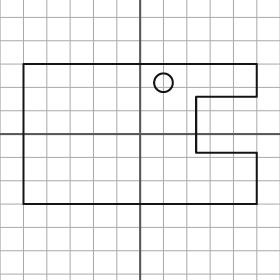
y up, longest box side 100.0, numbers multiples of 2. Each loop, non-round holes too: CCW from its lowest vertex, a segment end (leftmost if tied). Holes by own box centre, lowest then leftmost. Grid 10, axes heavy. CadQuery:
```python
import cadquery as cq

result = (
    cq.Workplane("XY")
    .moveTo(-50.0, -30.0)
    .lineTo(50.0, -30.0)
    .lineTo(50.0, -8.0)
    .lineTo(24.0, -8.0)
    .lineTo(24.0, 16.0)
    .lineTo(50.0, 16.0)
    .lineTo(50.0, 30.0)
    .lineTo(-50.0, 30.0)
    .close()
    .moveTo(10.0, 22.0)
    .circle(4.0)
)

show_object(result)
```